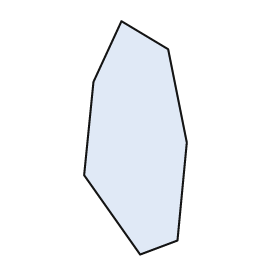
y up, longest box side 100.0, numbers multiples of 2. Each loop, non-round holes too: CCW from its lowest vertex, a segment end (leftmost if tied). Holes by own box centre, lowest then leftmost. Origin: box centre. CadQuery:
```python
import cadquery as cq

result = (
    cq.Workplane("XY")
    .moveTo(2.0, -50.0)
    .lineTo(18.0, -44.0)
    .lineTo(22.0, -2.0)
    .lineTo(14.0, 38.0)
    .lineTo(-6.0, 50.0)
    .lineTo(-18.0, 24.0)
    .lineTo(-22.0, -16.0)
    .close()
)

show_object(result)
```